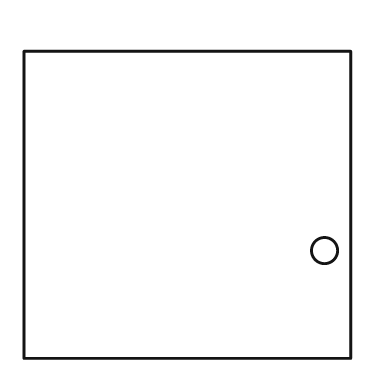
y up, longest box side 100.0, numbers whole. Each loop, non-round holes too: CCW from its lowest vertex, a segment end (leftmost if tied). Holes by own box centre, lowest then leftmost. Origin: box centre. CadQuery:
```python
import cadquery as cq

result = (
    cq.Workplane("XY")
    .moveTo(-50.0, -47.0)
    .lineTo(50.0, -47.0)
    .lineTo(50.0, 47.0)
    .lineTo(-50.0, 47.0)
    .close()
    .moveTo(42.0, -14.0)
    .circle(4.0)
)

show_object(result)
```